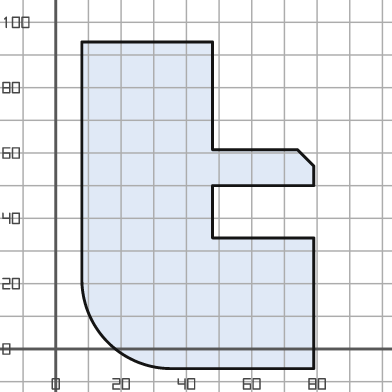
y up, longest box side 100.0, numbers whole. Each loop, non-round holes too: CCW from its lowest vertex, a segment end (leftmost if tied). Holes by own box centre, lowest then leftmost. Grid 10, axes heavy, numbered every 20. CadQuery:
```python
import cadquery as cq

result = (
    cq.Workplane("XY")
    .moveTo(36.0, -6.0)
    .lineTo(79.0, -6.0)
    .lineTo(79.0, 34.0)
    .lineTo(48.0, 34.0)
    .lineTo(48.0, 50.0)
    .lineTo(79.0, 50.0)
    .lineTo(79.0, 56.0)
    .lineTo(74.0, 61.0)
    .lineTo(48.0, 61.0)
    .lineTo(48.0, 94.0)
    .lineTo(8.0, 94.0)
    .lineTo(8.0, 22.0)
    .threePointArc((16.0, 2.0), (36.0, -6.0))
    .close()
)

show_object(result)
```